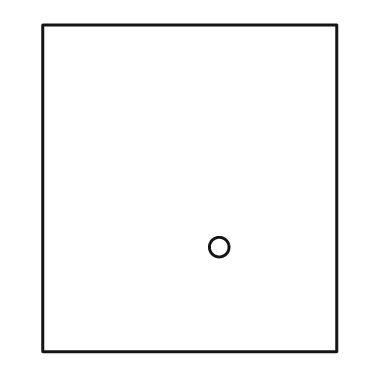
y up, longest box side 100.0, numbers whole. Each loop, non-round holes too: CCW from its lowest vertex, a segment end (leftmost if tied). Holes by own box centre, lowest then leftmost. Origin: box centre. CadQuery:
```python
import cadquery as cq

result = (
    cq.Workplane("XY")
    .moveTo(-45.0, -50.0)
    .lineTo(45.0, -50.0)
    .lineTo(45.0, 50.0)
    .lineTo(-45.0, 50.0)
    .close()
    .moveTo(9.0, -18.0)
    .circle(3.0)
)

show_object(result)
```